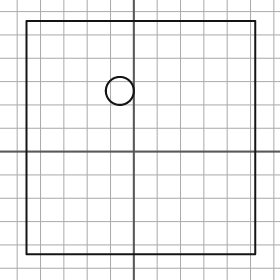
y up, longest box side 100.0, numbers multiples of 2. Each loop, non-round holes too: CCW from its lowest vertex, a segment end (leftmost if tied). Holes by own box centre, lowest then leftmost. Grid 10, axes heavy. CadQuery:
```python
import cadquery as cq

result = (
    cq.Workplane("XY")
    .moveTo(-46.0, -44.0)
    .lineTo(52.0, -44.0)
    .lineTo(52.0, 56.0)
    .lineTo(-46.0, 56.0)
    .close()
    .moveTo(-6.0, 26.0)
    .circle(6.0)
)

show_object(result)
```